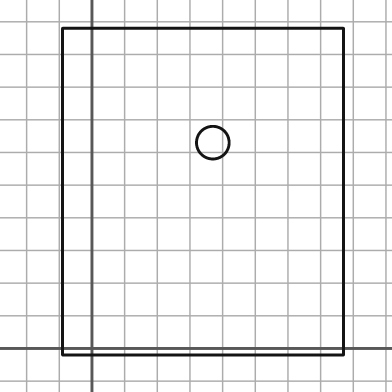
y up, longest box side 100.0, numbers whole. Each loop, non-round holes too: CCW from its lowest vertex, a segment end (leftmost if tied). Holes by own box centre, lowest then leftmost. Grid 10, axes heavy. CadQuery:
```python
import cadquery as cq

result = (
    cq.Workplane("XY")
    .moveTo(-9.0, -2.0)
    .lineTo(77.0, -2.0)
    .lineTo(77.0, 98.0)
    .lineTo(-9.0, 98.0)
    .close()
    .moveTo(37.0, 63.0)
    .circle(5.0)
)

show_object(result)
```